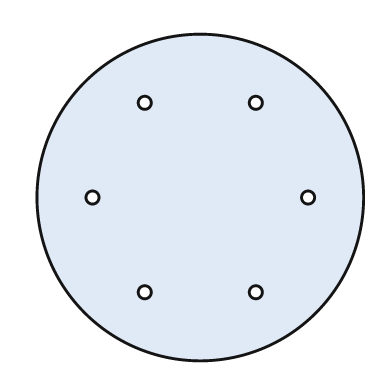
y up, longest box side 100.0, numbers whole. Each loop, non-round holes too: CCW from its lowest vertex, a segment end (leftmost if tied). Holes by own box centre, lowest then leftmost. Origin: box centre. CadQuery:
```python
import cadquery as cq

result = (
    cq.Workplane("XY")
    .moveTo(0.0, 0.0)
    .circle(50.0)
    .moveTo(-17.0, -29.0)
    .circle(2.0)
    .moveTo(17.0, -29.0)
    .circle(2.0)
    .moveTo(-33.0, 0.0)
    .circle(2.0)
    .moveTo(33.0, 0.0)
    .circle(2.0)
    .moveTo(-17.0, 29.0)
    .circle(2.0)
    .moveTo(17.0, 29.0)
    .circle(2.0)
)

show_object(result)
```